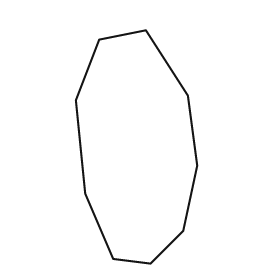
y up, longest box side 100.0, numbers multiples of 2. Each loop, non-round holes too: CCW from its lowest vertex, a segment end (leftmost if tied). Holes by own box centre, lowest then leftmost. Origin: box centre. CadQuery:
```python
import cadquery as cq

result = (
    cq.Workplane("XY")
    .moveTo(6.0, -50.0)
    .lineTo(20.0, -36.0)
    .lineTo(26.0, -8.0)
    .lineTo(22.0, 22.0)
    .lineTo(4.0, 50.0)
    .lineTo(-16.0, 46.0)
    .lineTo(-26.0, 20.0)
    .lineTo(-22.0, -20.0)
    .lineTo(-10.0, -48.0)
    .close()
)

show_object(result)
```